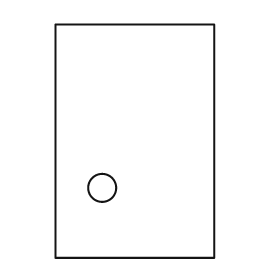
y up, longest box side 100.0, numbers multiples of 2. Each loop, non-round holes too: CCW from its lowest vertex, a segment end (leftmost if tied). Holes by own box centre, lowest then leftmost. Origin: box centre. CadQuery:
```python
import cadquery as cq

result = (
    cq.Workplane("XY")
    .moveTo(-34.0, -50.0)
    .lineTo(34.0, -50.0)
    .lineTo(34.0, 50.0)
    .lineTo(-34.0, 50.0)
    .close()
    .moveTo(-14.0, -20.0)
    .circle(6.0)
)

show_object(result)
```